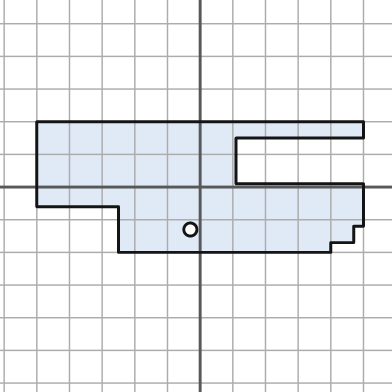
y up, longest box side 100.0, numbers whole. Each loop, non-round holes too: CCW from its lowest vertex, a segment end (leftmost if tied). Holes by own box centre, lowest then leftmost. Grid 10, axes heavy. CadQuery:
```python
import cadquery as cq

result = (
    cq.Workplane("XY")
    .moveTo(-25.0, -20.0)
    .lineTo(40.0, -20.0)
    .lineTo(40.0, -17.0)
    .lineTo(47.0, -17.0)
    .lineTo(47.0, -12.0)
    .lineTo(50.0, -12.0)
    .lineTo(50.0, 1.0)
    .lineTo(11.0, 1.0)
    .lineTo(11.0, 15.0)
    .lineTo(50.0, 15.0)
    .lineTo(50.0, 20.0)
    .lineTo(-50.0, 20.0)
    .lineTo(-50.0, -6.0)
    .lineTo(-25.0, -6.0)
    .close()
    .moveTo(-3.0, -13.0)
    .circle(2.0)
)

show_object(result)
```